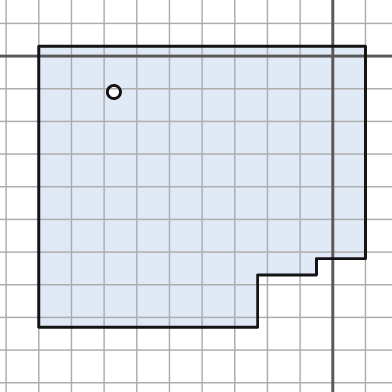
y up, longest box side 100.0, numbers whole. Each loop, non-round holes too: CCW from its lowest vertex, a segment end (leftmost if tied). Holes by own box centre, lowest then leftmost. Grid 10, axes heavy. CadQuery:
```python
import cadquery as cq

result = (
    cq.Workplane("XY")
    .moveTo(-90.0, -83.0)
    .lineTo(-23.0, -83.0)
    .lineTo(-23.0, -67.0)
    .lineTo(-5.0, -67.0)
    .lineTo(-5.0, -62.0)
    .lineTo(10.0, -62.0)
    .lineTo(10.0, 3.0)
    .lineTo(-90.0, 3.0)
    .close()
    .moveTo(-67.0, -11.0)
    .circle(2.0)
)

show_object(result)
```